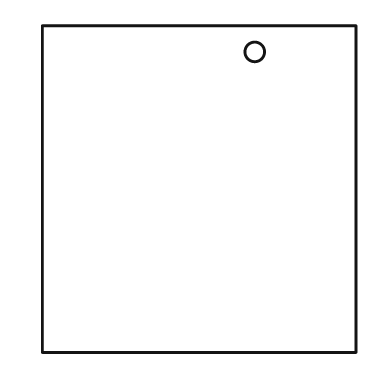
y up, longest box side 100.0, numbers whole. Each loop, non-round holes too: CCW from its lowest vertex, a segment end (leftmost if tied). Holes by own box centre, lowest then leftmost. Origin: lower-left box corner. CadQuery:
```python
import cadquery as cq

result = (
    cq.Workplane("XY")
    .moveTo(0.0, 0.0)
    .lineTo(96.0, 0.0)
    .lineTo(96.0, 100.0)
    .lineTo(0.0, 100.0)
    .close()
    .moveTo(65.0, 92.0)
    .circle(3.0)
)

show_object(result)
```